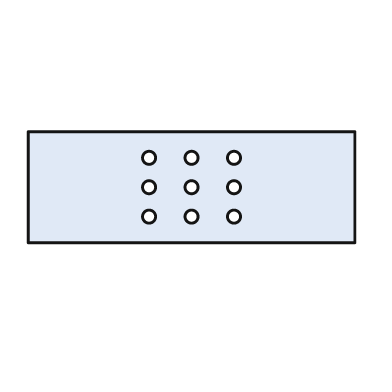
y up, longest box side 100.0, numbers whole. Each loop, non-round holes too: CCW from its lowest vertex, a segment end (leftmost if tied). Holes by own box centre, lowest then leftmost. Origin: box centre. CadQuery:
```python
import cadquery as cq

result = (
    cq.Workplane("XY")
    .moveTo(-50.0, -17.0)
    .lineTo(50.0, -17.0)
    .lineTo(50.0, 17.0)
    .lineTo(-50.0, 17.0)
    .close()
    .moveTo(-13.0, -9.0)
    .circle(2.0)
    .moveTo(0.0, -9.0)
    .circle(2.0)
    .moveTo(13.0, -9.0)
    .circle(2.0)
    .moveTo(-13.0, 0.0)
    .circle(2.0)
    .moveTo(0.0, 0.0)
    .circle(2.0)
    .moveTo(13.0, 0.0)
    .circle(2.0)
    .moveTo(-13.0, 9.0)
    .circle(2.0)
    .moveTo(0.0, 9.0)
    .circle(2.0)
    .moveTo(13.0, 9.0)
    .circle(2.0)
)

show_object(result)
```